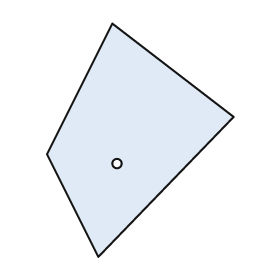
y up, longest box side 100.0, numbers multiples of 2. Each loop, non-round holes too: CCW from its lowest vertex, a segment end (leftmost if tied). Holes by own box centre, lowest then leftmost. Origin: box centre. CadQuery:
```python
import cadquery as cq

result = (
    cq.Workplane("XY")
    .moveTo(-18.0, -50.0)
    .lineTo(40.0, 10.0)
    .lineTo(-12.0, 50.0)
    .lineTo(-40.0, -6.0)
    .close()
    .moveTo(-10.0, -10.0)
    .circle(2.0)
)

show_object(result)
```